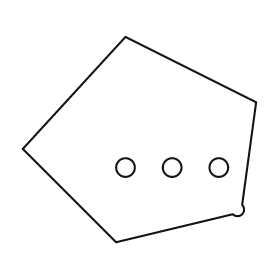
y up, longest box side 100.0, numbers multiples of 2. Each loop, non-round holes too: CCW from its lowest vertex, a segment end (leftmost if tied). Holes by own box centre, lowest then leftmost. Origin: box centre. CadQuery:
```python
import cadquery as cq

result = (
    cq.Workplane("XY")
    .moveTo(-10.0, -44.0)
    .lineTo(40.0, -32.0)
    .threePointArc((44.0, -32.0), (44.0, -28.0))
    .lineTo(50.0, 16.0)
    .lineTo(-6.0, 44.0)
    .lineTo(-50.0, -4.0)
    .close()
    .moveTo(-6.0, -12.0)
    .circle(4.0)
    .moveTo(14.0, -12.0)
    .circle(4.0)
    .moveTo(34.0, -12.0)
    .circle(4.0)
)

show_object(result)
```